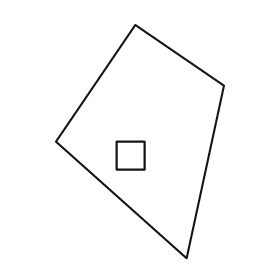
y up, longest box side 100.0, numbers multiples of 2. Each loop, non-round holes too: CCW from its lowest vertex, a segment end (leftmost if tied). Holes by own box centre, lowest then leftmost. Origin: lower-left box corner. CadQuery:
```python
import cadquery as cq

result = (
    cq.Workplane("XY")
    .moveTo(56.0, 0.0)
    .lineTo(72.0, 74.0)
    .lineTo(34.0, 100.0)
    .lineTo(0.0, 50.0)
    .close()
    .moveTo(26.0, 38.0)
    .lineTo(38.0, 38.0)
    .lineTo(38.0, 50.0)
    .lineTo(26.0, 50.0)
    .close()
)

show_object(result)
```